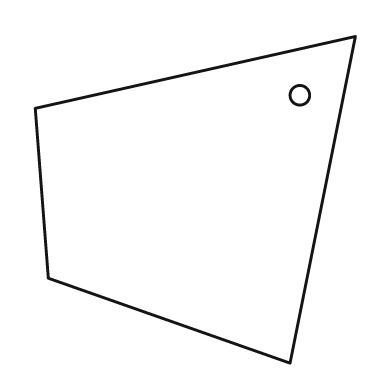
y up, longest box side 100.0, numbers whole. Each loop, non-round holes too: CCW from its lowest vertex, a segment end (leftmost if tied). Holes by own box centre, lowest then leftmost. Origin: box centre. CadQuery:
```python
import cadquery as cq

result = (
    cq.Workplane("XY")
    .moveTo(29.0, -50.0)
    .lineTo(49.0, 50.0)
    .lineTo(-49.0, 28.0)
    .lineTo(-45.0, -24.0)
    .close()
    .moveTo(32.0, 32.0)
    .circle(3.0)
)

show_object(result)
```